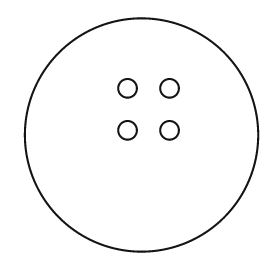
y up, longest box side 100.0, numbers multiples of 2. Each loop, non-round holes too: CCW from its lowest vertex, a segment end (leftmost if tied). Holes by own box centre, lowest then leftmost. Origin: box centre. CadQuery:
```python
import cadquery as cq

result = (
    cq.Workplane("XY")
    .moveTo(0.0, 0.0)
    .circle(50.0)
    .moveTo(-6.0, 2.0)
    .circle(4.0)
    .moveTo(12.0, 2.0)
    .circle(4.0)
    .moveTo(-6.0, 20.0)
    .circle(4.0)
    .moveTo(12.0, 20.0)
    .circle(4.0)
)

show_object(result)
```